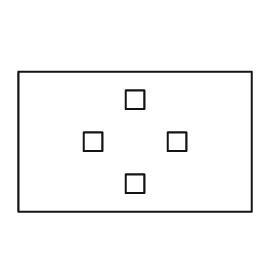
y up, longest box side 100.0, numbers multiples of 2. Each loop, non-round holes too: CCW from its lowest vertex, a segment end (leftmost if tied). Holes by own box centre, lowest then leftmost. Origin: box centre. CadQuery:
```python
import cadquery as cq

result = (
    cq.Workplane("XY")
    .moveTo(-50.0, -30.0)
    .lineTo(50.0, -30.0)
    .lineTo(50.0, 30.0)
    .lineTo(-50.0, 30.0)
    .close()
    .moveTo(-4.0, -22.0)
    .lineTo(4.0, -22.0)
    .lineTo(4.0, -14.0)
    .lineTo(-4.0, -14.0)
    .close()
    .moveTo(-22.0, -4.0)
    .lineTo(-14.0, -4.0)
    .lineTo(-14.0, 4.0)
    .lineTo(-22.0, 4.0)
    .close()
    .moveTo(14.0, -4.0)
    .lineTo(22.0, -4.0)
    .lineTo(22.0, 4.0)
    .lineTo(14.0, 4.0)
    .close()
    .moveTo(-4.0, 14.0)
    .lineTo(4.0, 14.0)
    .lineTo(4.0, 22.0)
    .lineTo(-4.0, 22.0)
    .close()
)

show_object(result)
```